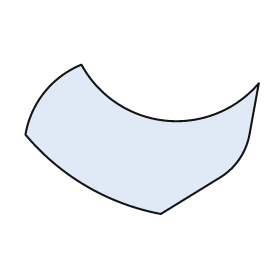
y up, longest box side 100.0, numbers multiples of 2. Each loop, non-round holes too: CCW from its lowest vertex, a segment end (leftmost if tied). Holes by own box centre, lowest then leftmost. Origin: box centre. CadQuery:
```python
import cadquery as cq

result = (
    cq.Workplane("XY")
    .moveTo(8.0, -32.0)
    .lineTo(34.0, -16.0)
    .threePointArc((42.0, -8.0), (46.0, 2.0))
    .lineTo(50.0, 24.0)
    .threePointArc((10.0, 8.0), (-26.0, 32.0))
    .threePointArc((-42.0, 20.0), (-50.0, 2.0))
    .threePointArc((-24.0, -20.0), (8.0, -32.0))
    .close()
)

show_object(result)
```